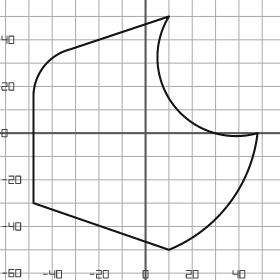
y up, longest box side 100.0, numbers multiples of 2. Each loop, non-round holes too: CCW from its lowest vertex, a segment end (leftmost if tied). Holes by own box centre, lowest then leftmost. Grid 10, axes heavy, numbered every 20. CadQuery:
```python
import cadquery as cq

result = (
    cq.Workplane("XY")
    .moveTo(10.0, -50.0)
    .threePointArc((36.0, -30.0), (48.0, 0.0))
    .threePointArc((12.0, 12.0), (10.0, 50.0))
    .lineTo(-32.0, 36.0)
    .threePointArc((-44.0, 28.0), (-48.0, 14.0))
    .lineTo(-48.0, -30.0)
    .close()
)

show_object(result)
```